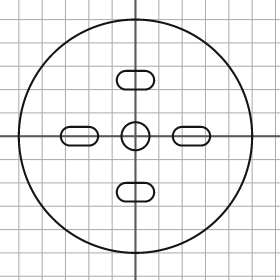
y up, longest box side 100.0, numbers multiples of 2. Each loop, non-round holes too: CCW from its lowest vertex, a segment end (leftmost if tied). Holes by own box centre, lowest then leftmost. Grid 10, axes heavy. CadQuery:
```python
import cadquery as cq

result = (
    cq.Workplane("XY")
    .moveTo(0.0, 0.0)
    .circle(50.0)
    .moveTo(-4.0, -28.0)
    .lineTo(4.0, -28.0)
    .threePointArc((8.0, -24.0), (4.0, -20.0))
    .lineTo(-4.0, -20.0)
    .threePointArc((-8.0, -24.0), (-4.0, -28.0))
    .close()
    .moveTo(-28.0, -4.0)
    .lineTo(-20.0, -4.0)
    .threePointArc((-16.0, 0.0), (-20.0, 4.0))
    .lineTo(-28.0, 4.0)
    .threePointArc((-32.0, 0.0), (-28.0, -4.0))
    .close()
    .moveTo(0.0, 0.0)
    .circle(6.0)
    .moveTo(20.0, -4.0)
    .lineTo(28.0, -4.0)
    .threePointArc((32.0, 0.0), (28.0, 4.0))
    .lineTo(20.0, 4.0)
    .threePointArc((16.0, 0.0), (20.0, -4.0))
    .close()
    .moveTo(-4.0, 20.0)
    .lineTo(4.0, 20.0)
    .threePointArc((8.0, 24.0), (4.0, 28.0))
    .lineTo(-4.0, 28.0)
    .threePointArc((-8.0, 24.0), (-4.0, 20.0))
    .close()
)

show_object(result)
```